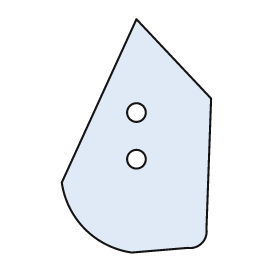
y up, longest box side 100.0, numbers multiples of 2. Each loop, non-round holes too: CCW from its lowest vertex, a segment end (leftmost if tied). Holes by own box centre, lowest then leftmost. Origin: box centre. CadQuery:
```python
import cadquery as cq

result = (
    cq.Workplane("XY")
    .moveTo(-2.0, -50.0)
    .lineTo(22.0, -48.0)
    .threePointArc((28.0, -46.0), (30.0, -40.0))
    .lineTo(32.0, 16.0)
    .lineTo(0.0, 50.0)
    .lineTo(-32.0, -20.0)
    .threePointArc((-22.0, -40.0), (-2.0, -50.0))
    .close()
    .moveTo(0.0, -10.0)
    .circle(4.0)
    .moveTo(0.0, 10.0)
    .circle(4.0)
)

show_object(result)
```